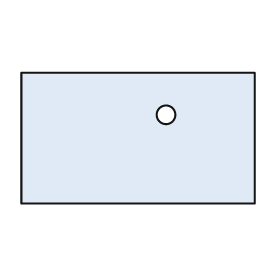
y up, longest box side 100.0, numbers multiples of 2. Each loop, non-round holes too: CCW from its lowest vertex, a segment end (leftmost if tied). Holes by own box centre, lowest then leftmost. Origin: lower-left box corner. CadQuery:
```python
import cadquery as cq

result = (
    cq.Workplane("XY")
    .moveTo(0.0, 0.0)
    .lineTo(100.0, 0.0)
    .lineTo(100.0, 56.0)
    .lineTo(0.0, 56.0)
    .close()
    .moveTo(62.0, 38.0)
    .circle(4.0)
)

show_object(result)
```